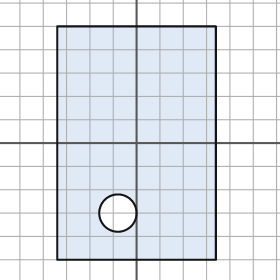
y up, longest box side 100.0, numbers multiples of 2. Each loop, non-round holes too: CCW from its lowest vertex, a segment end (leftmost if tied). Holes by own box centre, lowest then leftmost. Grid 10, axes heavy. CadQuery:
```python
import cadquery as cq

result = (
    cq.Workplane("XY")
    .moveTo(-34.0, -50.0)
    .lineTo(34.0, -50.0)
    .lineTo(34.0, 50.0)
    .lineTo(-34.0, 50.0)
    .close()
    .moveTo(-8.0, -30.0)
    .circle(8.0)
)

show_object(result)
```